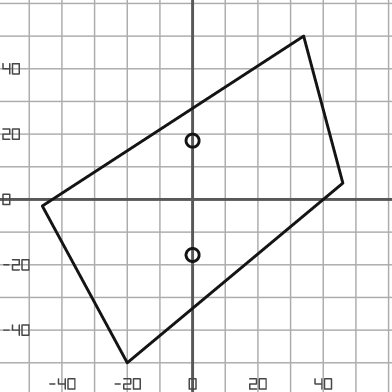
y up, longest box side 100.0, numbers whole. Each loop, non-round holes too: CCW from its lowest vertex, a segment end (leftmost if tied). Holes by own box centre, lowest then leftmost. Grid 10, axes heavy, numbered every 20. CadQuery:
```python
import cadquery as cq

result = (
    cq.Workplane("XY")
    .moveTo(-20.0, -50.0)
    .lineTo(46.0, 5.0)
    .lineTo(34.0, 50.0)
    .lineTo(-46.0, -2.0)
    .close()
    .moveTo(0.0, -17.0)
    .circle(2.0)
    .moveTo(0.0, 18.0)
    .circle(2.0)
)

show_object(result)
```